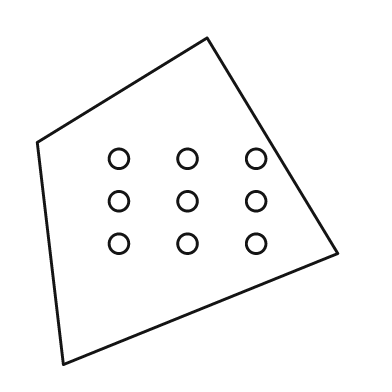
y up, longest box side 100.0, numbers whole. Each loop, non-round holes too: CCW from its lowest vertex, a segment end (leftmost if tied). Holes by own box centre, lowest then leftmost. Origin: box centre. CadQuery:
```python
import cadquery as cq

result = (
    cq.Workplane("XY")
    .moveTo(-38.0, -50.0)
    .lineTo(46.0, -16.0)
    .lineTo(6.0, 50.0)
    .lineTo(-46.0, 18.0)
    .close()
    .moveTo(-21.0, -13.0)
    .circle(3.0)
    .moveTo(0.0, -13.0)
    .circle(3.0)
    .moveTo(21.0, -13.0)
    .circle(3.0)
    .moveTo(-21.0, 0.0)
    .circle(3.0)
    .moveTo(0.0, 0.0)
    .circle(3.0)
    .moveTo(21.0, 0.0)
    .circle(3.0)
    .moveTo(-21.0, 13.0)
    .circle(3.0)
    .moveTo(0.0, 13.0)
    .circle(3.0)
    .moveTo(21.0, 13.0)
    .circle(3.0)
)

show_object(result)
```